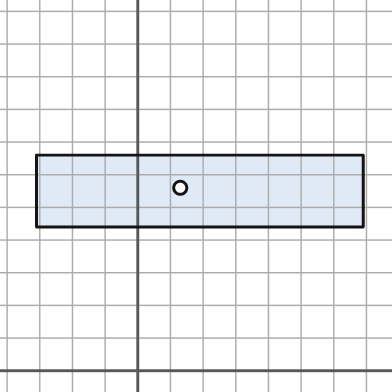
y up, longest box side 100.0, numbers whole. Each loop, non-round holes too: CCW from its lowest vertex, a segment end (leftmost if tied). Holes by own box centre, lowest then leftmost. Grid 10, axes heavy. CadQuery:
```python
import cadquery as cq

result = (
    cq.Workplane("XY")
    .moveTo(-31.0, 44.0)
    .lineTo(69.0, 44.0)
    .lineTo(69.0, 66.0)
    .lineTo(-31.0, 66.0)
    .close()
    .moveTo(13.0, 56.0)
    .circle(2.0)
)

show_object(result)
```